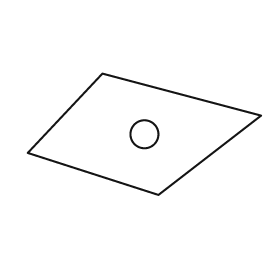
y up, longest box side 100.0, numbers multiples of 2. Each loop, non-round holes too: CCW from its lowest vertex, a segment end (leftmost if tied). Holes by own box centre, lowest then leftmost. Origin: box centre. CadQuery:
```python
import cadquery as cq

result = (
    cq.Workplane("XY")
    .moveTo(6.0, -26.0)
    .lineTo(50.0, 8.0)
    .lineTo(-18.0, 26.0)
    .lineTo(-50.0, -8.0)
    .close()
    .moveTo(0.0, 0.0)
    .circle(6.0)
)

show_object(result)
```